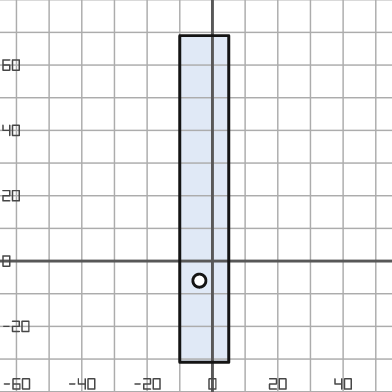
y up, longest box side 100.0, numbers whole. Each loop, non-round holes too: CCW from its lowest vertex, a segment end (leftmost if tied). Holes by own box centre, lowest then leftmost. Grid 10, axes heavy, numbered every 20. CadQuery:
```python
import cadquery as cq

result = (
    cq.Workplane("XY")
    .moveTo(-10.0, -31.0)
    .lineTo(5.0, -31.0)
    .lineTo(5.0, 69.0)
    .lineTo(-10.0, 69.0)
    .close()
    .moveTo(-4.0, -6.0)
    .circle(2.0)
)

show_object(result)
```